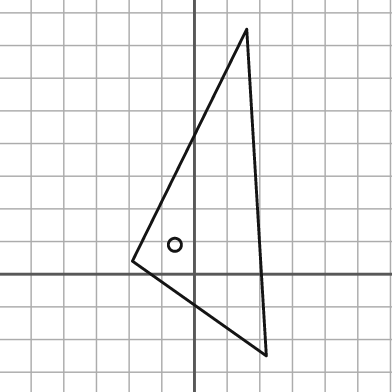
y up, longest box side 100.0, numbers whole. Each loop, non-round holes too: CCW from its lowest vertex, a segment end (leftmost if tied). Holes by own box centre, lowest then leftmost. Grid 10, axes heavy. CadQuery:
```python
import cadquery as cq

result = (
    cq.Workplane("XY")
    .moveTo(22.0, -25.0)
    .lineTo(16.0, 75.0)
    .lineTo(-19.0, 4.0)
    .close()
    .moveTo(-6.0, 9.0)
    .circle(2.0)
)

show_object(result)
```